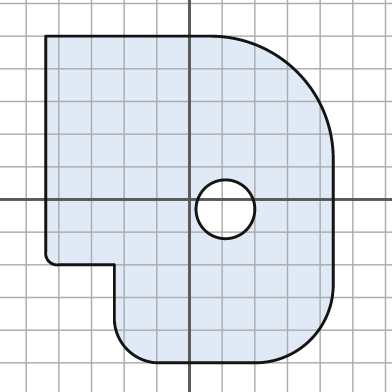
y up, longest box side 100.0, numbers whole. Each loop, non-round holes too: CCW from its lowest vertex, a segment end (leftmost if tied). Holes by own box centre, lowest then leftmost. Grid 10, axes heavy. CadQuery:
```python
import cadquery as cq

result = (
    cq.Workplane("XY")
    .moveTo(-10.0, -50.0)
    .lineTo(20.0, -50.0)
    .threePointArc((37.0, -43.0), (44.0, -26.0))
    .lineTo(44.0, 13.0)
    .threePointArc((33.0, 39.0), (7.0, 50.0))
    .lineTo(-44.0, 50.0)
    .lineTo(-44.0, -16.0)
    .threePointArc((-43.0, -19.0), (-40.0, -20.0))
    .lineTo(-23.0, -20.0)
    .lineTo(-23.0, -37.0)
    .threePointArc((-19.0, -46.0), (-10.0, -50.0))
    .close()
    .moveTo(11.0, -3.0)
    .circle(9.0)
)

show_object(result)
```